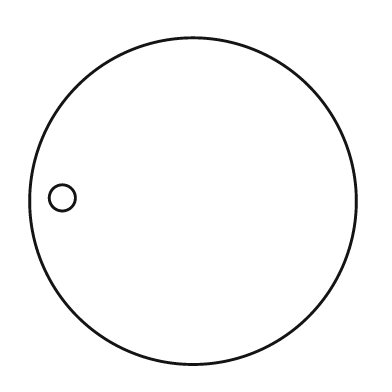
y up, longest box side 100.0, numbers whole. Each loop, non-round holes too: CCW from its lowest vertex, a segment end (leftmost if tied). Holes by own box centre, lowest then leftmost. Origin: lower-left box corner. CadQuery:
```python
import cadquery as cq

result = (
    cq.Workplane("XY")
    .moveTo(50.0, 50.0)
    .circle(50.0)
    .moveTo(10.0, 51.0)
    .circle(4.0)
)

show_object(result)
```